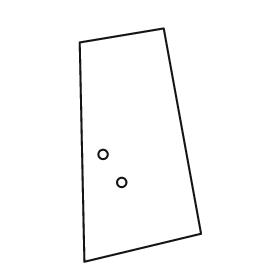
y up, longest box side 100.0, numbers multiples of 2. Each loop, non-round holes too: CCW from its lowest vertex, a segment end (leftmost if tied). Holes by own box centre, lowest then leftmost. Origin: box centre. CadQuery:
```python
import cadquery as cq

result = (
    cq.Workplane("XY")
    .moveTo(-24.0, -50.0)
    .lineTo(26.0, -38.0)
    .lineTo(10.0, 50.0)
    .lineTo(-26.0, 44.0)
    .close()
    .moveTo(-8.0, -16.0)
    .circle(2.0)
    .moveTo(-16.0, -4.0)
    .circle(2.0)
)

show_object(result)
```